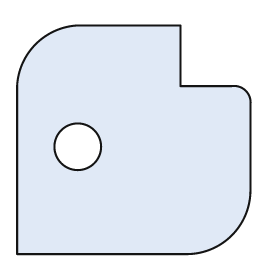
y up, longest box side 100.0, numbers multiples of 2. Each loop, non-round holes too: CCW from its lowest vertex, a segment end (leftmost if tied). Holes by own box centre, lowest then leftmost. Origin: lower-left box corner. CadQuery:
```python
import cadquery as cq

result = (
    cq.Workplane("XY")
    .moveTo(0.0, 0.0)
    .lineTo(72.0, 0.0)
    .threePointArc((92.0, 8.0), (100.0, 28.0))
    .lineTo(100.0, 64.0)
    .threePointArc((98.0, 70.0), (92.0, 72.0))
    .lineTo(70.0, 72.0)
    .lineTo(70.0, 98.0)
    .lineTo(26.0, 98.0)
    .threePointArc((8.0, 90.0), (0.0, 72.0))
    .close()
    .moveTo(26.0, 46.0)
    .circle(10.0)
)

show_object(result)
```